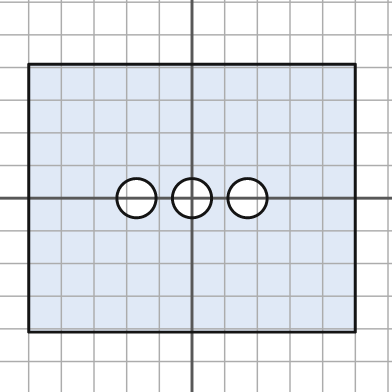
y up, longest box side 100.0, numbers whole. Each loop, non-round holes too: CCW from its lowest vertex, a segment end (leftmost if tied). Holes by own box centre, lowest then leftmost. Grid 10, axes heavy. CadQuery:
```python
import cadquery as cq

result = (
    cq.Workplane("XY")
    .moveTo(-50.0, -41.0)
    .lineTo(50.0, -41.0)
    .lineTo(50.0, 41.0)
    .lineTo(-50.0, 41.0)
    .close()
    .moveTo(-17.0, 0.0)
    .circle(6.0)
    .moveTo(0.0, 0.0)
    .circle(6.0)
    .moveTo(17.0, 0.0)
    .circle(6.0)
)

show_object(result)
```